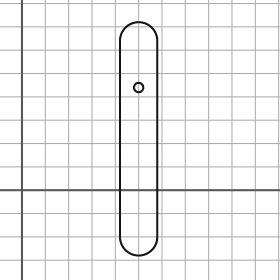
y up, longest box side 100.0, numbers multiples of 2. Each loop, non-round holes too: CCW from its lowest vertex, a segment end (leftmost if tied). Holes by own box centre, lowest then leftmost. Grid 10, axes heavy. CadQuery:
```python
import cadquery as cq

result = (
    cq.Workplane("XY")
    .moveTo(42.0, -20.0)
    .threePointArc((50.0, -28.0), (58.0, -20.0))
    .lineTo(58.0, 64.0)
    .threePointArc((50.0, 72.0), (42.0, 64.0))
    .close()
    .moveTo(50.0, 44.0)
    .circle(2.0)
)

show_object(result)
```